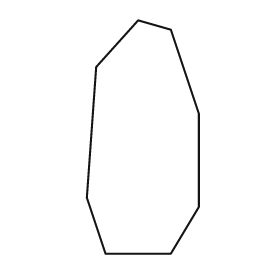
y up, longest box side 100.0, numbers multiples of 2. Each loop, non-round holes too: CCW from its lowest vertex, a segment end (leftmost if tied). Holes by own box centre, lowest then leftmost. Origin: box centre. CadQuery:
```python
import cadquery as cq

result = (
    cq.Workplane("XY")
    .moveTo(-16.0, -50.0)
    .lineTo(12.0, -50.0)
    .lineTo(24.0, -30.0)
    .lineTo(24.0, 10.0)
    .lineTo(12.0, 46.0)
    .lineTo(-2.0, 50.0)
    .lineTo(-20.0, 30.0)
    .lineTo(-24.0, -26.0)
    .close()
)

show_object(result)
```